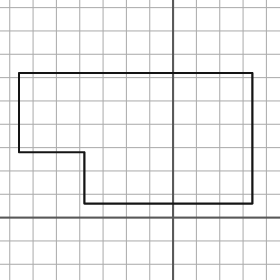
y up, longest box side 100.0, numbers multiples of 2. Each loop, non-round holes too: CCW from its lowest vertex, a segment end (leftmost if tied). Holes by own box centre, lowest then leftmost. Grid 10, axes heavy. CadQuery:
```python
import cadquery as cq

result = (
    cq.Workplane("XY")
    .moveTo(-38.0, 6.0)
    .lineTo(34.0, 6.0)
    .lineTo(34.0, 62.0)
    .lineTo(-66.0, 62.0)
    .lineTo(-66.0, 28.0)
    .lineTo(-38.0, 28.0)
    .close()
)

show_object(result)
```